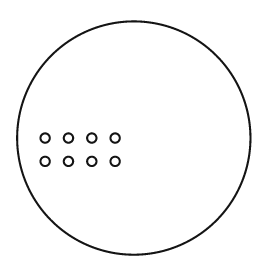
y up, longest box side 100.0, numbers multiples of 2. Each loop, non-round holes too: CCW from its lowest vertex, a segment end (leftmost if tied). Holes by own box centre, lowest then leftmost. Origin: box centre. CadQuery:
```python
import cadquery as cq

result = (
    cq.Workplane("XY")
    .moveTo(0.0, 0.0)
    .circle(50.0)
    .moveTo(-38.0, -10.0)
    .circle(2.0)
    .moveTo(-28.0, -10.0)
    .circle(2.0)
    .moveTo(-18.0, -10.0)
    .circle(2.0)
    .moveTo(-8.0, -10.0)
    .circle(2.0)
    .moveTo(-38.0, 0.0)
    .circle(2.0)
    .moveTo(-28.0, 0.0)
    .circle(2.0)
    .moveTo(-18.0, 0.0)
    .circle(2.0)
    .moveTo(-8.0, 0.0)
    .circle(2.0)
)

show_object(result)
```